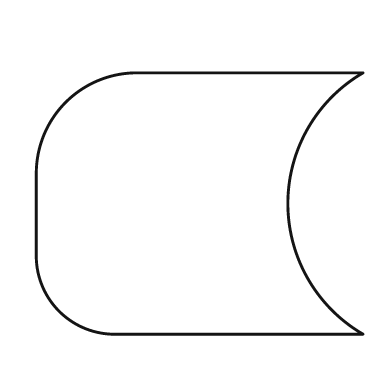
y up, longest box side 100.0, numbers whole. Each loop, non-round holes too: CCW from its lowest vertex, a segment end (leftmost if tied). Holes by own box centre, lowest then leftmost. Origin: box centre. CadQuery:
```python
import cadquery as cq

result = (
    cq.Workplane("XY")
    .moveTo(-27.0, -40.0)
    .lineTo(50.0, -40.0)
    .threePointArc((27.0, 0.0), (50.0, 40.0))
    .lineTo(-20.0, 40.0)
    .threePointArc((-41.0, 31.0), (-50.0, 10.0))
    .lineTo(-50.0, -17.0)
    .threePointArc((-43.0, -33.0), (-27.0, -40.0))
    .close()
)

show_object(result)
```